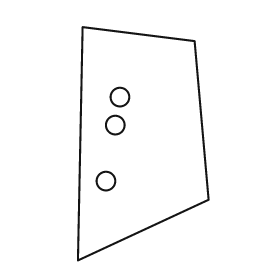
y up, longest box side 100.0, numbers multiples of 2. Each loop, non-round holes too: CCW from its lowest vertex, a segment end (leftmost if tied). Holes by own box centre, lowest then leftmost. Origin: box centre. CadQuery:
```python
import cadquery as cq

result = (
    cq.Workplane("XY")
    .moveTo(-28.0, -50.0)
    .lineTo(28.0, -24.0)
    .lineTo(22.0, 44.0)
    .lineTo(-26.0, 50.0)
    .close()
    .moveTo(-16.0, -16.0)
    .circle(4.0)
    .moveTo(-12.0, 8.0)
    .circle(4.0)
    .moveTo(-10.0, 20.0)
    .circle(4.0)
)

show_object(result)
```